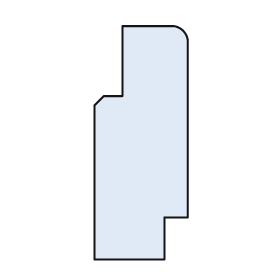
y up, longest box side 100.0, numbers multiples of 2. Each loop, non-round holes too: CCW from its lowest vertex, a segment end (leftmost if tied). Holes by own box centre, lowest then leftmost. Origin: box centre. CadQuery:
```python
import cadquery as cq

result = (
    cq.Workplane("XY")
    .moveTo(-20.0, -50.0)
    .lineTo(10.0, -50.0)
    .lineTo(10.0, -32.0)
    .lineTo(20.0, -32.0)
    .lineTo(20.0, 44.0)
    .threePointArc((18.0, 48.0), (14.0, 50.0))
    .lineTo(-8.0, 50.0)
    .lineTo(-8.0, 20.0)
    .lineTo(-16.0, 20.0)
    .lineTo(-20.0, 16.0)
    .close()
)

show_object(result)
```